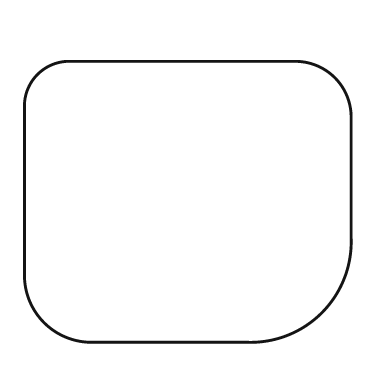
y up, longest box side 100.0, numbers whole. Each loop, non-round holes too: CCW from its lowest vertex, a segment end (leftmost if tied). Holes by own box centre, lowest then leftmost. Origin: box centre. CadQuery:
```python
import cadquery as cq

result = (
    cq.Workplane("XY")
    .moveTo(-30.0, -43.0)
    .lineTo(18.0, -43.0)
    .threePointArc((41.0, -34.0), (50.0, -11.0))
    .lineTo(50.0, 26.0)
    .threePointArc((45.0, 38.0), (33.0, 43.0))
    .lineTo(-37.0, 43.0)
    .threePointArc((-46.0, 39.0), (-50.0, 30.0))
    .lineTo(-50.0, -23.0)
    .threePointArc((-44.0, -37.0), (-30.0, -43.0))
    .close()
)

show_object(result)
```